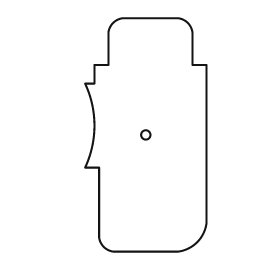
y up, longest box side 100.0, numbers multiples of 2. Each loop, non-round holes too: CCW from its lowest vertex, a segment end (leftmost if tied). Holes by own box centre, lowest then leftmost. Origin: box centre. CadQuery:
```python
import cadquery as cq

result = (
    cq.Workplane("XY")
    .moveTo(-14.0, -50.0)
    .lineTo(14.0, -50.0)
    .threePointArc((22.0, -46.0), (26.0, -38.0))
    .lineTo(26.0, 30.0)
    .lineTo(20.0, 30.0)
    .lineTo(20.0, 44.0)
    .threePointArc((18.0, 48.0), (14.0, 50.0))
    .lineTo(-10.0, 50.0)
    .threePointArc((-14.0, 48.0), (-16.0, 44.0))
    .lineTo(-16.0, 30.0)
    .lineTo(-22.0, 30.0)
    .lineTo(-22.0, 22.0)
    .lineTo(-26.0, 22.0)
    .threePointArc((-22.0, 4.0), (-26.0, -14.0))
    .lineTo(-20.0, -14.0)
    .lineTo(-20.0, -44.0)
    .threePointArc((-18.0, -48.0), (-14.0, -50.0))
    .close()
    .moveTo(0.0, 0.0)
    .circle(2.0)
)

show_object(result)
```